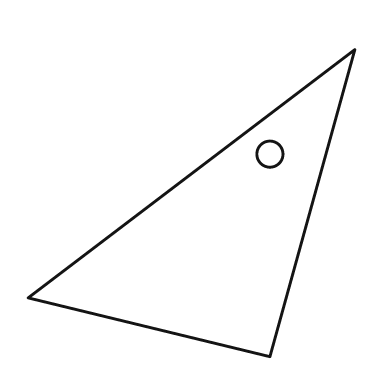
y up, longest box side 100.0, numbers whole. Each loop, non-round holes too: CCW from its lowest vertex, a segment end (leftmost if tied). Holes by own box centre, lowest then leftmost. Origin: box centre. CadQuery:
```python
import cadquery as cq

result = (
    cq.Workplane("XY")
    .moveTo(24.0, -47.0)
    .lineTo(50.0, 47.0)
    .lineTo(-50.0, -29.0)
    .close()
    .moveTo(24.0, 15.0)
    .circle(4.0)
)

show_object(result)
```